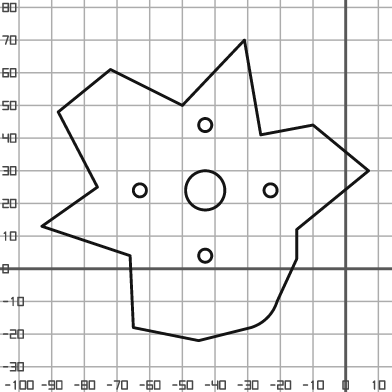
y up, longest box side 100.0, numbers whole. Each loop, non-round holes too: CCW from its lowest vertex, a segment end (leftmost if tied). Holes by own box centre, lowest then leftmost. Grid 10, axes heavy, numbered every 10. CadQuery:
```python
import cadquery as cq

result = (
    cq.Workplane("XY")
    .moveTo(-45.0, -22.0)
    .lineTo(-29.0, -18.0)
    .threePointArc((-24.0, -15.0), (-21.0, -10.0))
    .lineTo(-15.0, 3.0)
    .lineTo(-15.0, 12.0)
    .lineTo(7.0, 30.0)
    .lineTo(-10.0, 44.0)
    .lineTo(-26.0, 41.0)
    .lineTo(-31.0, 70.0)
    .lineTo(-50.0, 50.0)
    .lineTo(-72.0, 61.0)
    .lineTo(-88.0, 48.0)
    .lineTo(-76.0, 25.0)
    .lineTo(-93.0, 13.0)
    .lineTo(-66.0, 4.0)
    .lineTo(-65.0, -18.0)
    .close()
    .moveTo(-43.0, 4.0)
    .circle(2.0)
    .moveTo(-63.0, 24.0)
    .circle(2.0)
    .moveTo(-43.0, 24.0)
    .circle(6.0)
    .moveTo(-23.0, 24.0)
    .circle(2.0)
    .moveTo(-43.0, 44.0)
    .circle(2.0)
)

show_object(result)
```